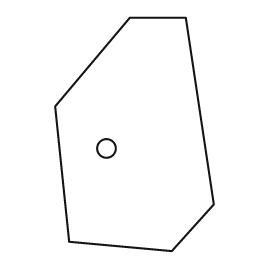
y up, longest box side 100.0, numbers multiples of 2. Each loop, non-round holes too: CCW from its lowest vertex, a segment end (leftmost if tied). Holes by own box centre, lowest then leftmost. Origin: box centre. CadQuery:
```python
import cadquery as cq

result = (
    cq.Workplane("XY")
    .moveTo(16.0, -50.0)
    .lineTo(34.0, -30.0)
    .lineTo(22.0, 50.0)
    .lineTo(-2.0, 50.0)
    .lineTo(-34.0, 12.0)
    .lineTo(-28.0, -46.0)
    .close()
    .moveTo(-12.0, -6.0)
    .circle(4.0)
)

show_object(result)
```